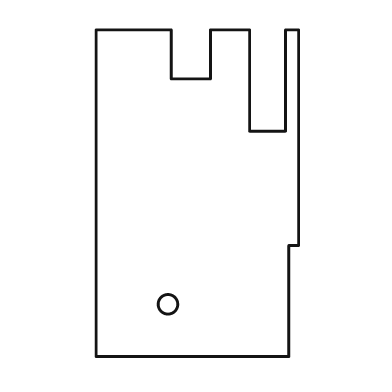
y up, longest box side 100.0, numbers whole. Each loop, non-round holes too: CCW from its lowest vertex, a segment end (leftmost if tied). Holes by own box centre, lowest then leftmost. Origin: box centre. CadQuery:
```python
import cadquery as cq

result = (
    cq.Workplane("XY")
    .moveTo(-31.0, -50.0)
    .lineTo(28.0, -50.0)
    .lineTo(28.0, -16.0)
    .lineTo(31.0, -16.0)
    .lineTo(31.0, 50.0)
    .lineTo(27.0, 50.0)
    .lineTo(27.0, 19.0)
    .lineTo(16.0, 19.0)
    .lineTo(16.0, 50.0)
    .lineTo(4.0, 50.0)
    .lineTo(4.0, 35.0)
    .lineTo(-8.0, 35.0)
    .lineTo(-8.0, 50.0)
    .lineTo(-31.0, 50.0)
    .close()
    .moveTo(-9.0, -34.0)
    .circle(3.0)
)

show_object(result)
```